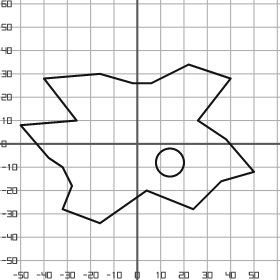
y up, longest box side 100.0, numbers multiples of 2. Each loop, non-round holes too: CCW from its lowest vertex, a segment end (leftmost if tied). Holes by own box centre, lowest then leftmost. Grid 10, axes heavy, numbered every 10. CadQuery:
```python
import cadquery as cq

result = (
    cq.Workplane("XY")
    .moveTo(-16.0, -34.0)
    .lineTo(4.0, -20.0)
    .lineTo(24.0, -28.0)
    .lineTo(36.0, -16.0)
    .lineTo(50.0, -12.0)
    .lineTo(38.0, 2.0)
    .lineTo(26.0, 10.0)
    .lineTo(40.0, 28.0)
    .lineTo(22.0, 34.0)
    .lineTo(6.0, 26.0)
    .lineTo(-2.0, 26.0)
    .lineTo(-16.0, 30.0)
    .lineTo(-40.0, 28.0)
    .lineTo(-26.0, 10.0)
    .lineTo(-50.0, 8.0)
    .lineTo(-38.0, -6.0)
    .lineTo(-32.0, -10.0)
    .lineTo(-28.0, -18.0)
    .lineTo(-32.0, -28.0)
    .close()
    .moveTo(14.0, -8.0)
    .circle(6.0)
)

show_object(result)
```